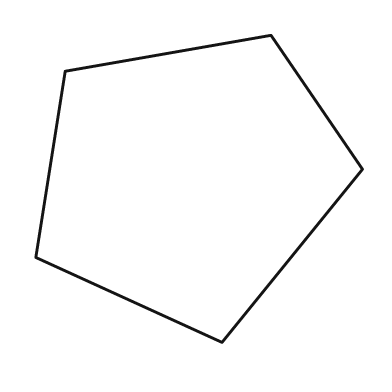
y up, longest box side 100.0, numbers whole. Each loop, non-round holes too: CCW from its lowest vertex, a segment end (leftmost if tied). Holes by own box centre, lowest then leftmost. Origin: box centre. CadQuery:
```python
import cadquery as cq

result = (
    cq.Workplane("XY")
    .moveTo(7.0, -47.0)
    .lineTo(50.0, 6.0)
    .lineTo(22.0, 47.0)
    .lineTo(-41.0, 36.0)
    .lineTo(-50.0, -21.0)
    .close()
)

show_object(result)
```